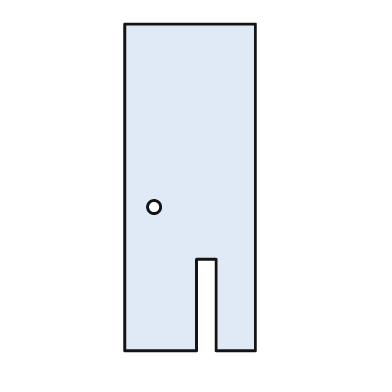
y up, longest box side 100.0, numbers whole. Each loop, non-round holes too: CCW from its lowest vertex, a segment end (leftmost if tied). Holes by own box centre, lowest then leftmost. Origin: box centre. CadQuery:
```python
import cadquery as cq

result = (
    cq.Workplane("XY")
    .moveTo(-20.0, -50.0)
    .lineTo(2.0, -50.0)
    .lineTo(2.0, -22.0)
    .lineTo(8.0, -22.0)
    .lineTo(8.0, -50.0)
    .lineTo(20.0, -50.0)
    .lineTo(20.0, 50.0)
    .lineTo(-20.0, 50.0)
    .close()
    .moveTo(-11.0, -6.0)
    .circle(2.0)
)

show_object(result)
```